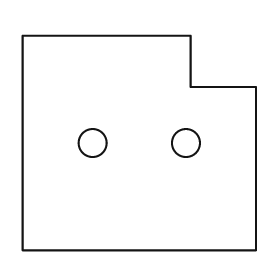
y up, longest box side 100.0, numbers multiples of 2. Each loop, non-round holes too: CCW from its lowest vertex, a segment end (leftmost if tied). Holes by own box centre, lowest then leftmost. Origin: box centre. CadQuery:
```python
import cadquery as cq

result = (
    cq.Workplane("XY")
    .moveTo(-50.0, -46.0)
    .lineTo(50.0, -46.0)
    .lineTo(50.0, 24.0)
    .lineTo(22.0, 24.0)
    .lineTo(22.0, 46.0)
    .lineTo(-50.0, 46.0)
    .close()
    .moveTo(-20.0, 0.0)
    .circle(6.0)
    .moveTo(20.0, 0.0)
    .circle(6.0)
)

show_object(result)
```